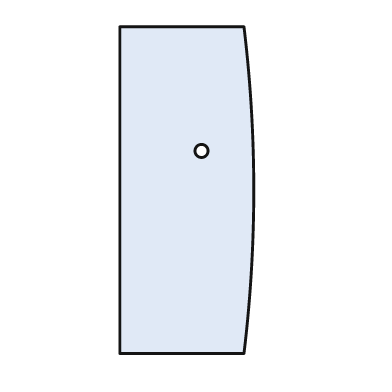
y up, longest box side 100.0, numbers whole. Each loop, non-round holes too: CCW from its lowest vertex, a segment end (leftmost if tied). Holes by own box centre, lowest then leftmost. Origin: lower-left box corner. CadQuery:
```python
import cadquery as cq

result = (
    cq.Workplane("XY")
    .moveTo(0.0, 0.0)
    .lineTo(38.0, 0.0)
    .threePointArc((41.0, 50.0), (38.0, 100.0))
    .lineTo(0.0, 100.0)
    .close()
    .moveTo(25.0, 62.0)
    .circle(2.0)
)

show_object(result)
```